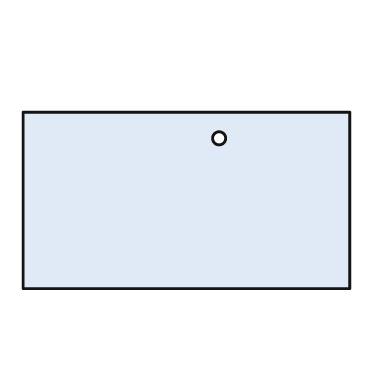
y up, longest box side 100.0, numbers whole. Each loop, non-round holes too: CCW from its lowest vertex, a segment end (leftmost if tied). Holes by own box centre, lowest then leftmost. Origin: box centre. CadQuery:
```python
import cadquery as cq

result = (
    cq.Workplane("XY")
    .moveTo(-50.0, -27.0)
    .lineTo(50.0, -27.0)
    .lineTo(50.0, 27.0)
    .lineTo(-50.0, 27.0)
    .close()
    .moveTo(10.0, 19.0)
    .circle(2.0)
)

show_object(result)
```